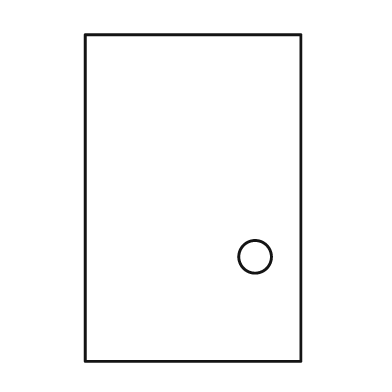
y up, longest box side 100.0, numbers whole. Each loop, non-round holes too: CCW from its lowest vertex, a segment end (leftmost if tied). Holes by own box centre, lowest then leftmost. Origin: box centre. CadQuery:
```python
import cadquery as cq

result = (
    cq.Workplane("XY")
    .moveTo(-33.0, -50.0)
    .lineTo(33.0, -50.0)
    .lineTo(33.0, 50.0)
    .lineTo(-33.0, 50.0)
    .close()
    .moveTo(19.0, -18.0)
    .circle(5.0)
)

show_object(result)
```